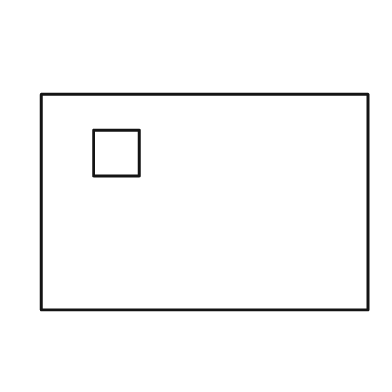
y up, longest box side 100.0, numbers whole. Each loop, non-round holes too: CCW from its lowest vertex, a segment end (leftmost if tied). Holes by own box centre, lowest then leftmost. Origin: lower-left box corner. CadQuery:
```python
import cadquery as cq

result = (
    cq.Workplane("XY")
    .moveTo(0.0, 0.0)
    .lineTo(100.0, 0.0)
    .lineTo(100.0, 66.0)
    .lineTo(0.0, 66.0)
    .close()
    .moveTo(16.0, 41.0)
    .lineTo(30.0, 41.0)
    .lineTo(30.0, 55.0)
    .lineTo(16.0, 55.0)
    .close()
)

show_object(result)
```